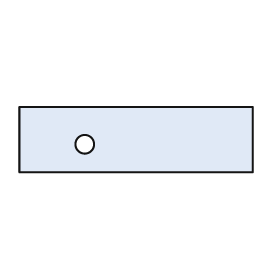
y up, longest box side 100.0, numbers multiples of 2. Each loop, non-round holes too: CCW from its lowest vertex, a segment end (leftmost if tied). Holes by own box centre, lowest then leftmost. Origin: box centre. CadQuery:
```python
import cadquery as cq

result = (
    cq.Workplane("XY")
    .moveTo(-50.0, -14.0)
    .lineTo(50.0, -14.0)
    .lineTo(50.0, 14.0)
    .lineTo(-50.0, 14.0)
    .close()
    .moveTo(-22.0, -2.0)
    .circle(4.0)
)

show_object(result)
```